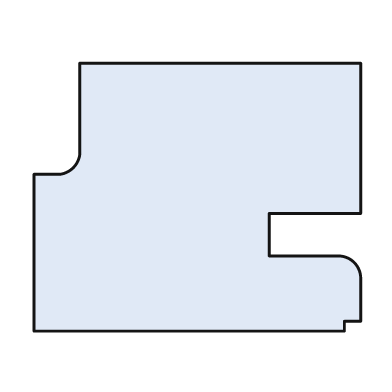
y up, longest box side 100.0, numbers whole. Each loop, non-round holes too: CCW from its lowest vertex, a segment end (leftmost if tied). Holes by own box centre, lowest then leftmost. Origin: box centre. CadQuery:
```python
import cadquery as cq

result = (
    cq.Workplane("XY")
    .moveTo(-50.0, -41.0)
    .lineTo(45.0, -41.0)
    .lineTo(45.0, -38.0)
    .lineTo(50.0, -38.0)
    .lineTo(50.0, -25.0)
    .threePointArc((48.0, -20.0), (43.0, -18.0))
    .lineTo(22.0, -18.0)
    .lineTo(22.0, -5.0)
    .lineTo(50.0, -5.0)
    .lineTo(50.0, 41.0)
    .lineTo(-36.0, 41.0)
    .lineTo(-36.0, 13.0)
    .threePointArc((-38.0, 9.0), (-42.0, 7.0))
    .lineTo(-50.0, 7.0)
    .close()
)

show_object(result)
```